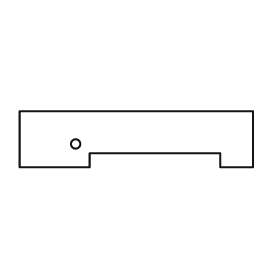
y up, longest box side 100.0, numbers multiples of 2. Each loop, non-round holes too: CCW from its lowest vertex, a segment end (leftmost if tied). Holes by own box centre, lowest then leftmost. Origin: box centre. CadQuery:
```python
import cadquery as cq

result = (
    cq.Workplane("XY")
    .moveTo(-50.0, -12.0)
    .lineTo(-20.0, -12.0)
    .lineTo(-20.0, -6.0)
    .lineTo(36.0, -6.0)
    .lineTo(36.0, -12.0)
    .lineTo(50.0, -12.0)
    .lineTo(50.0, 12.0)
    .lineTo(-50.0, 12.0)
    .close()
    .moveTo(-26.0, -2.0)
    .circle(2.0)
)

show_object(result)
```